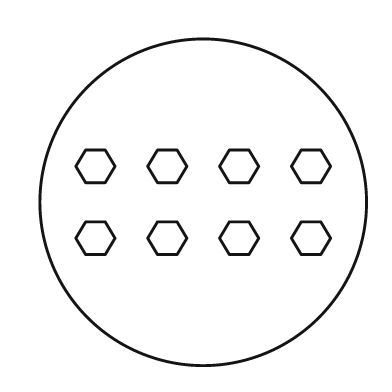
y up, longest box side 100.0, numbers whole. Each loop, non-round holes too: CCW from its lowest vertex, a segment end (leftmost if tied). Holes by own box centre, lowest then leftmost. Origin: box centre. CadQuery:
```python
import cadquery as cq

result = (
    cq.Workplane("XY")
    .moveTo(0.0, 0.0)
    .circle(50.0)
    .moveTo(-36.0, -16.0)
    .lineTo(-30.0, -16.0)
    .lineTo(-27.0, -11.0)
    .lineTo(-30.0, -6.0)
    .lineTo(-36.0, -6.0)
    .lineTo(-39.0, -11.0)
    .close()
    .moveTo(-14.0, -16.0)
    .lineTo(-8.0, -16.0)
    .lineTo(-5.0, -11.0)
    .lineTo(-8.0, -6.0)
    .lineTo(-14.0, -6.0)
    .lineTo(-17.0, -11.0)
    .close()
    .moveTo(8.0, -16.0)
    .lineTo(14.0, -16.0)
    .lineTo(17.0, -11.0)
    .lineTo(14.0, -6.0)
    .lineTo(8.0, -6.0)
    .lineTo(5.0, -11.0)
    .close()
    .moveTo(30.0, -16.0)
    .lineTo(36.0, -16.0)
    .lineTo(39.0, -11.0)
    .lineTo(36.0, -6.0)
    .lineTo(30.0, -6.0)
    .lineTo(27.0, -11.0)
    .close()
    .moveTo(-36.0, 6.0)
    .lineTo(-30.0, 6.0)
    .lineTo(-27.0, 11.0)
    .lineTo(-30.0, 16.0)
    .lineTo(-36.0, 16.0)
    .lineTo(-39.0, 11.0)
    .close()
    .moveTo(-14.0, 6.0)
    .lineTo(-8.0, 6.0)
    .lineTo(-5.0, 11.0)
    .lineTo(-8.0, 16.0)
    .lineTo(-14.0, 16.0)
    .lineTo(-17.0, 11.0)
    .close()
    .moveTo(8.0, 6.0)
    .lineTo(14.0, 6.0)
    .lineTo(17.0, 11.0)
    .lineTo(14.0, 16.0)
    .lineTo(8.0, 16.0)
    .lineTo(5.0, 11.0)
    .close()
    .moveTo(30.0, 6.0)
    .lineTo(36.0, 6.0)
    .lineTo(39.0, 11.0)
    .lineTo(36.0, 16.0)
    .lineTo(30.0, 16.0)
    .lineTo(27.0, 11.0)
    .close()
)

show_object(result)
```